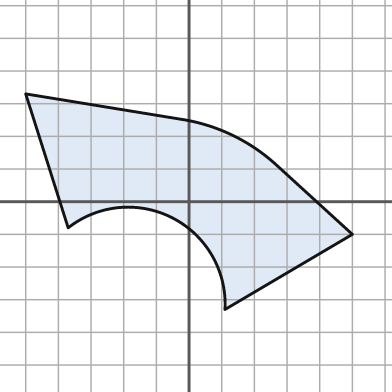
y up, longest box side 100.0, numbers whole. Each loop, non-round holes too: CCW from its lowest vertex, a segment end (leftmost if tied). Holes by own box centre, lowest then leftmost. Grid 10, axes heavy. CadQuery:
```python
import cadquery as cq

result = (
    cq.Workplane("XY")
    .moveTo(11.0, -33.0)
    .lineTo(50.0, -10.0)
    .lineTo(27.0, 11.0)
    .threePointArc((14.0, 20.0), (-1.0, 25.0))
    .lineTo(-50.0, 33.0)
    .lineTo(-37.0, -8.0)
    .threePointArc((-5.0, -5.0), (11.0, -33.0))
    .close()
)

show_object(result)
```